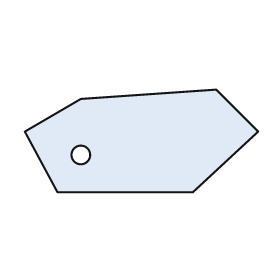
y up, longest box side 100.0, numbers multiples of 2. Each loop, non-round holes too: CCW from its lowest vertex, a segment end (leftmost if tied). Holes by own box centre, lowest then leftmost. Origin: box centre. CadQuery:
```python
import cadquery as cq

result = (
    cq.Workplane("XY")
    .moveTo(-36.0, -22.0)
    .lineTo(22.0, -22.0)
    .lineTo(50.0, 4.0)
    .lineTo(32.0, 22.0)
    .lineTo(-26.0, 18.0)
    .lineTo(-50.0, 4.0)
    .close()
    .moveTo(-26.0, -6.0)
    .circle(4.0)
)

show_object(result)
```